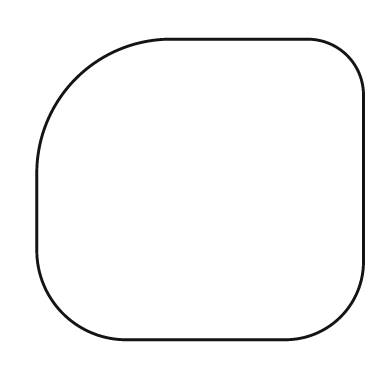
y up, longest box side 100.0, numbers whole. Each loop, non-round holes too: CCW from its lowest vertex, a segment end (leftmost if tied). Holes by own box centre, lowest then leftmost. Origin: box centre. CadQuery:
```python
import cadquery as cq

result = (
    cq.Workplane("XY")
    .moveTo(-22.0, -46.0)
    .lineTo(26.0, -46.0)
    .threePointArc((43.0, -39.0), (50.0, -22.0))
    .lineTo(50.0, 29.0)
    .threePointArc((45.0, 41.0), (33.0, 46.0))
    .lineTo(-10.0, 46.0)
    .threePointArc((-38.0, 34.0), (-50.0, 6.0))
    .lineTo(-50.0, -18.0)
    .threePointArc((-42.0, -38.0), (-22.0, -46.0))
    .close()
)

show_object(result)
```